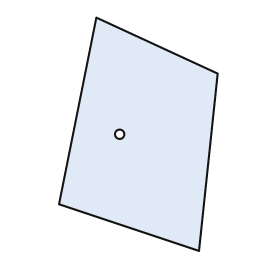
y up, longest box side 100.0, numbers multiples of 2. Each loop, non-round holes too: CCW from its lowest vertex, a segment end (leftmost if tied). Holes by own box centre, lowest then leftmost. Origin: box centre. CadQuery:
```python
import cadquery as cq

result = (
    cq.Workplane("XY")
    .moveTo(26.0, -50.0)
    .lineTo(34.0, 26.0)
    .lineTo(-18.0, 50.0)
    .lineTo(-34.0, -30.0)
    .close()
    .moveTo(-8.0, 0.0)
    .circle(2.0)
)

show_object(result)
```